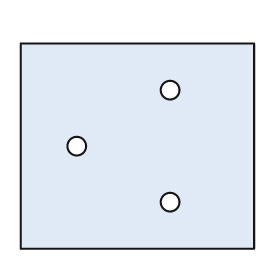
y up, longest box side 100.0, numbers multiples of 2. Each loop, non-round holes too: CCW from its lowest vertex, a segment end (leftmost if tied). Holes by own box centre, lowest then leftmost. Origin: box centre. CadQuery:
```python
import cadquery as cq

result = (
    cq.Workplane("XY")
    .moveTo(-50.0, -44.0)
    .lineTo(50.0, -44.0)
    .lineTo(50.0, 44.0)
    .lineTo(-50.0, 44.0)
    .close()
    .moveTo(14.0, -24.0)
    .circle(4.0)
    .moveTo(-26.0, 0.0)
    .circle(4.0)
    .moveTo(14.0, 24.0)
    .circle(4.0)
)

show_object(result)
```